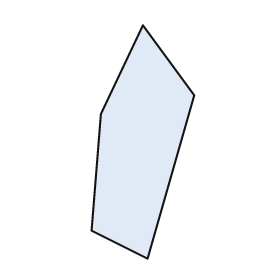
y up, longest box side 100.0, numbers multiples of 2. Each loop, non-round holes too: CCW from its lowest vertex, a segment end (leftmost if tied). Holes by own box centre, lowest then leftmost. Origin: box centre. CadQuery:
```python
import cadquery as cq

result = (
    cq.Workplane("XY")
    .moveTo(2.0, -50.0)
    .lineTo(22.0, 20.0)
    .lineTo(0.0, 50.0)
    .lineTo(-18.0, 12.0)
    .lineTo(-22.0, -38.0)
    .close()
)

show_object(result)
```